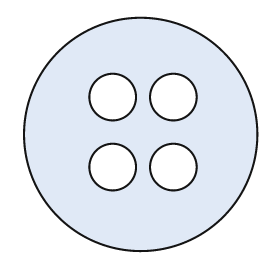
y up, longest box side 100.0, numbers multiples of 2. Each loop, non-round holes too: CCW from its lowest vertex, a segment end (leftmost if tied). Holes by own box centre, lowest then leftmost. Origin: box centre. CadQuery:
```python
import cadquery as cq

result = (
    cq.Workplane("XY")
    .moveTo(0.0, 0.0)
    .circle(50.0)
    .moveTo(-12.0, -14.0)
    .circle(10.0)
    .moveTo(14.0, -14.0)
    .circle(10.0)
    .moveTo(-12.0, 16.0)
    .circle(10.0)
    .moveTo(14.0, 16.0)
    .circle(10.0)
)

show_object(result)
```